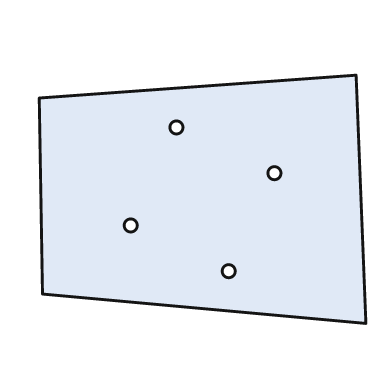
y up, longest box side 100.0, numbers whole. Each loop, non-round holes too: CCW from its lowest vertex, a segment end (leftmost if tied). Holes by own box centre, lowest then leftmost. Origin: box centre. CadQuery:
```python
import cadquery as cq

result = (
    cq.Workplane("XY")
    .moveTo(50.0, -38.0)
    .lineTo(47.0, 38.0)
    .lineTo(-50.0, 31.0)
    .lineTo(-49.0, -29.0)
    .close()
    .moveTo(8.0, -22.0)
    .circle(2.0)
    .moveTo(-22.0, -8.0)
    .circle(2.0)
    .moveTo(22.0, 8.0)
    .circle(2.0)
    .moveTo(-8.0, 22.0)
    .circle(2.0)
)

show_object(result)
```